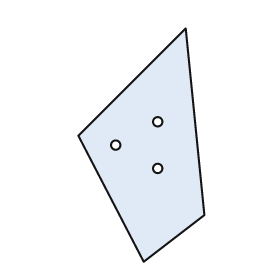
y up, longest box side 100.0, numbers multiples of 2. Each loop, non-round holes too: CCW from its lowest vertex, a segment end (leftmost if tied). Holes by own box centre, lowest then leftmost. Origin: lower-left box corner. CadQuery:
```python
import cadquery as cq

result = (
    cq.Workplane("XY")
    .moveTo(28.0, 0.0)
    .lineTo(54.0, 20.0)
    .lineTo(46.0, 100.0)
    .lineTo(0.0, 54.0)
    .close()
    .moveTo(34.0, 40.0)
    .circle(2.0)
    .moveTo(16.0, 50.0)
    .circle(2.0)
    .moveTo(34.0, 60.0)
    .circle(2.0)
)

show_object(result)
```